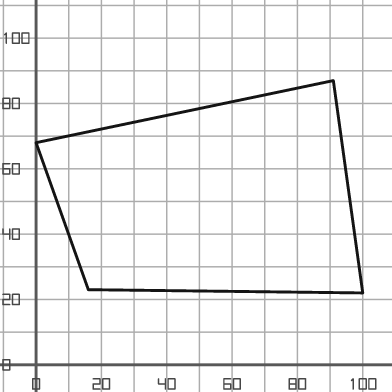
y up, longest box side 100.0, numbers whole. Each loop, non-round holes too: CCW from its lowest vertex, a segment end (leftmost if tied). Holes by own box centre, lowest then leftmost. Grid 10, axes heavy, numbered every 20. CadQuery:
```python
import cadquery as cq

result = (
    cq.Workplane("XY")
    .moveTo(100.0, 22.0)
    .lineTo(91.0, 87.0)
    .lineTo(0.0, 68.0)
    .lineTo(16.0, 23.0)
    .close()
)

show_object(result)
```